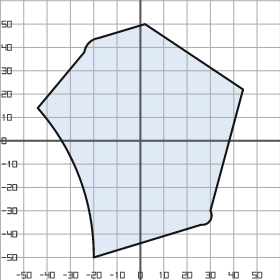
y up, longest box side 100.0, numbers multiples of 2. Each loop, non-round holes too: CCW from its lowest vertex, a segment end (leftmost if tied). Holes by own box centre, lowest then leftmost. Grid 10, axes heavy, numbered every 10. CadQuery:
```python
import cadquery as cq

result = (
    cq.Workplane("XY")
    .moveTo(-20.0, -50.0)
    .lineTo(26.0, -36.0)
    .threePointArc((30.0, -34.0), (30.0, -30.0))
    .lineTo(44.0, 22.0)
    .lineTo(2.0, 50.0)
    .lineTo(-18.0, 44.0)
    .threePointArc((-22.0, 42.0), (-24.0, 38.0))
    .lineTo(-44.0, 14.0)
    .threePointArc((-26.0, -16.0), (-20.0, -50.0))
    .close()
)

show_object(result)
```